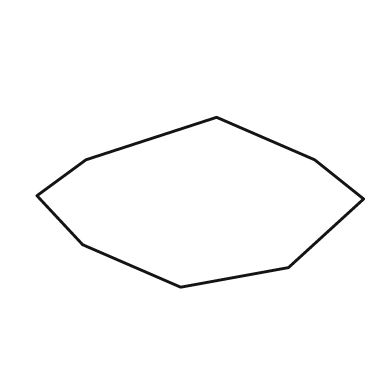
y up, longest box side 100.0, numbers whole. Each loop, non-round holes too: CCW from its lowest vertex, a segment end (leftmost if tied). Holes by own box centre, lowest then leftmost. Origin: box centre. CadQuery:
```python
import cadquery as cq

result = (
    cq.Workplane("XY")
    .moveTo(-6.0, -26.0)
    .lineTo(27.0, -20.0)
    .lineTo(50.0, 1.0)
    .lineTo(35.0, 13.0)
    .lineTo(5.0, 26.0)
    .lineTo(-35.0, 13.0)
    .lineTo(-50.0, 2.0)
    .lineTo(-36.0, -13.0)
    .close()
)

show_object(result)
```